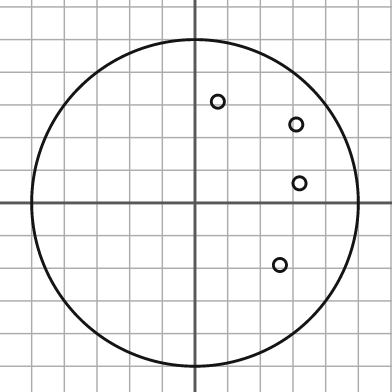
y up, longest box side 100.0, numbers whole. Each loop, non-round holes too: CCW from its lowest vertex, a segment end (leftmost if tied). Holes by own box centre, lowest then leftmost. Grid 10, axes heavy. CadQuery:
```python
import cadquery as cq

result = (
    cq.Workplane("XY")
    .moveTo(0.0, 0.0)
    .circle(50.0)
    .moveTo(26.0, -19.0)
    .circle(2.0)
    .moveTo(32.0, 6.0)
    .circle(2.0)
    .moveTo(31.0, 24.0)
    .circle(2.0)
    .moveTo(7.0, 31.0)
    .circle(2.0)
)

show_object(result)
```